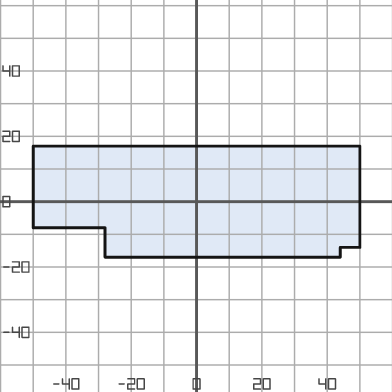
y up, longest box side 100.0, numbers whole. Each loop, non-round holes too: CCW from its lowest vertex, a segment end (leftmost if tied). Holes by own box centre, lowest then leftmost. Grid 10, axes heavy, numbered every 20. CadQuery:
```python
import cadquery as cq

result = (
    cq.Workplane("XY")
    .moveTo(-28.0, -17.0)
    .lineTo(44.0, -17.0)
    .lineTo(44.0, -14.0)
    .lineTo(50.0, -14.0)
    .lineTo(50.0, 17.0)
    .lineTo(-50.0, 17.0)
    .lineTo(-50.0, -8.0)
    .lineTo(-28.0, -8.0)
    .close()
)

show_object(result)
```